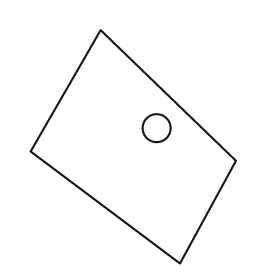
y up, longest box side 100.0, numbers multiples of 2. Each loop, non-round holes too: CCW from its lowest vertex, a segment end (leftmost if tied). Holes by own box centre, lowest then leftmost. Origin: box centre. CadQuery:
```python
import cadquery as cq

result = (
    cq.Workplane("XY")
    .moveTo(20.0, -50.0)
    .lineTo(44.0, -6.0)
    .lineTo(-14.0, 50.0)
    .lineTo(-44.0, -2.0)
    .close()
    .moveTo(10.0, 8.0)
    .circle(6.0)
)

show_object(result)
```